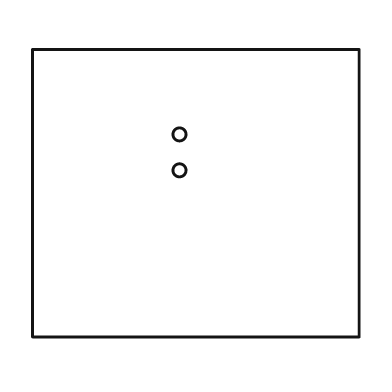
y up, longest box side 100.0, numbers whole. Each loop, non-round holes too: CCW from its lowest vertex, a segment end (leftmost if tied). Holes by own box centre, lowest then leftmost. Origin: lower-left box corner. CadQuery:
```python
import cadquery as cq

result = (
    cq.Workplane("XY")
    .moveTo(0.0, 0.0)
    .lineTo(100.0, 0.0)
    .lineTo(100.0, 88.0)
    .lineTo(0.0, 88.0)
    .close()
    .moveTo(45.0, 51.0)
    .circle(2.0)
    .moveTo(45.0, 62.0)
    .circle(2.0)
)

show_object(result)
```